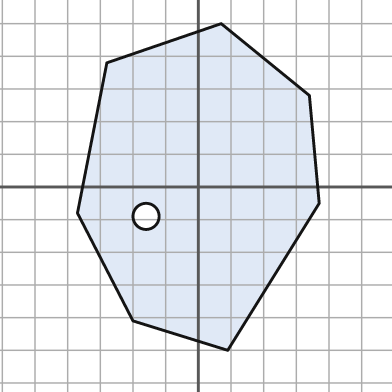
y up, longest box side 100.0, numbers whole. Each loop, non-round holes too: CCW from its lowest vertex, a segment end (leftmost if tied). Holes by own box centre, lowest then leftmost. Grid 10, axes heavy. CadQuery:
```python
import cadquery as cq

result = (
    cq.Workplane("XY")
    .moveTo(9.0, -50.0)
    .lineTo(37.0, -5.0)
    .lineTo(34.0, 28.0)
    .lineTo(7.0, 50.0)
    .lineTo(-28.0, 38.0)
    .lineTo(-37.0, -8.0)
    .lineTo(-20.0, -41.0)
    .close()
    .moveTo(-16.0, -9.0)
    .circle(4.0)
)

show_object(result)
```